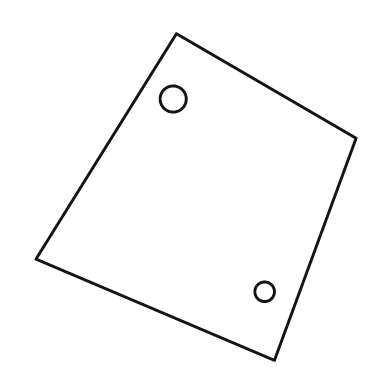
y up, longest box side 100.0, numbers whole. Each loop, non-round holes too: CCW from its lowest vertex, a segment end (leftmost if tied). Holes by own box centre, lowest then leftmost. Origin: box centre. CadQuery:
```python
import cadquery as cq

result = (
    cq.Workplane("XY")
    .moveTo(24.0, -50.0)
    .lineTo(49.0, 18.0)
    .lineTo(-6.0, 50.0)
    .lineTo(-49.0, -19.0)
    .close()
    .moveTo(21.0, -29.0)
    .circle(3.0)
    .moveTo(-7.0, 30.0)
    .circle(4.0)
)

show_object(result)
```